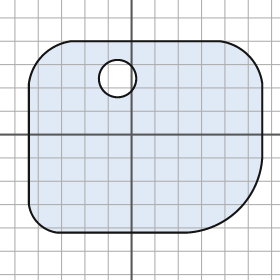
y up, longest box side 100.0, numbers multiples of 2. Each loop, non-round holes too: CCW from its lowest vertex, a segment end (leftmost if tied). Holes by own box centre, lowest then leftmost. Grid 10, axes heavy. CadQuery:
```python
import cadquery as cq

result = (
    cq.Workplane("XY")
    .moveTo(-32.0, -42.0)
    .lineTo(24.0, -42.0)
    .threePointArc((46.0, -32.0), (56.0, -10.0))
    .lineTo(56.0, 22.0)
    .threePointArc((50.0, 34.0), (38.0, 40.0))
    .lineTo(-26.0, 40.0)
    .threePointArc((-38.0, 34.0), (-44.0, 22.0))
    .lineTo(-44.0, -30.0)
    .threePointArc((-40.0, -38.0), (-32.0, -42.0))
    .close()
    .moveTo(-6.0, 24.0)
    .circle(8.0)
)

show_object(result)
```